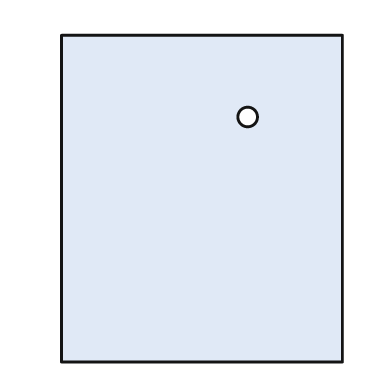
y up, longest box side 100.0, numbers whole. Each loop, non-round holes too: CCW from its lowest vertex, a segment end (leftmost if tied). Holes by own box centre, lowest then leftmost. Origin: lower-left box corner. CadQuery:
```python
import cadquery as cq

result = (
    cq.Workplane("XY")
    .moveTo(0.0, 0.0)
    .lineTo(86.0, 0.0)
    .lineTo(86.0, 100.0)
    .lineTo(0.0, 100.0)
    .close()
    .moveTo(57.0, 75.0)
    .circle(3.0)
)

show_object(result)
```